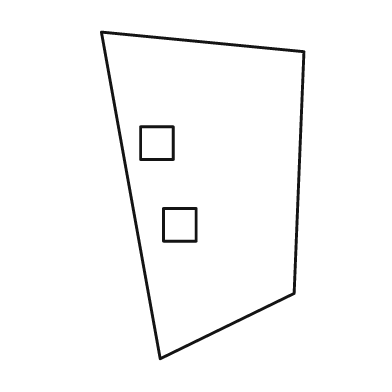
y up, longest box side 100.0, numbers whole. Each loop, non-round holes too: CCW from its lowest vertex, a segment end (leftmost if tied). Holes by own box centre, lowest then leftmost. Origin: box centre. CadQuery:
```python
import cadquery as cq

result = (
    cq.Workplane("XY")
    .moveTo(-13.0, -50.0)
    .lineTo(28.0, -30.0)
    .lineTo(31.0, 44.0)
    .lineTo(-31.0, 50.0)
    .close()
    .moveTo(-12.0, -14.0)
    .lineTo(-2.0, -14.0)
    .lineTo(-2.0, -4.0)
    .lineTo(-12.0, -4.0)
    .close()
    .moveTo(-19.0, 11.0)
    .lineTo(-9.0, 11.0)
    .lineTo(-9.0, 21.0)
    .lineTo(-19.0, 21.0)
    .close()
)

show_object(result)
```